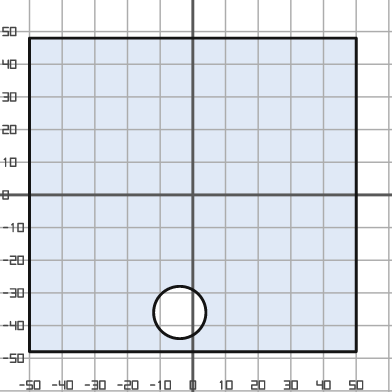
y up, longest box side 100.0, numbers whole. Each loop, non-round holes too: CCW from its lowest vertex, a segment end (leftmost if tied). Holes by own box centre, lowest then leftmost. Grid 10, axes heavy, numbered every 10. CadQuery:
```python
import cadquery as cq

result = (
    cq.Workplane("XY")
    .moveTo(-50.0, -48.0)
    .lineTo(50.0, -48.0)
    .lineTo(50.0, 48.0)
    .lineTo(-50.0, 48.0)
    .close()
    .moveTo(-4.0, -36.0)
    .circle(8.0)
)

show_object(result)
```